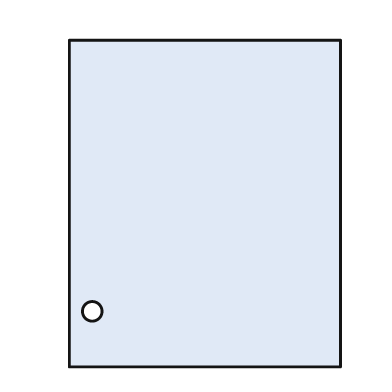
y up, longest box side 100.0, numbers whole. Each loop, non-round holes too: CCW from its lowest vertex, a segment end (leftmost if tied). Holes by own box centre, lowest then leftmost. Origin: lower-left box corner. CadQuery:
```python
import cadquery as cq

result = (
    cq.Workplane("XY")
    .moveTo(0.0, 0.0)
    .lineTo(83.0, 0.0)
    .lineTo(83.0, 100.0)
    .lineTo(0.0, 100.0)
    .close()
    .moveTo(7.0, 17.0)
    .circle(3.0)
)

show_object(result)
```